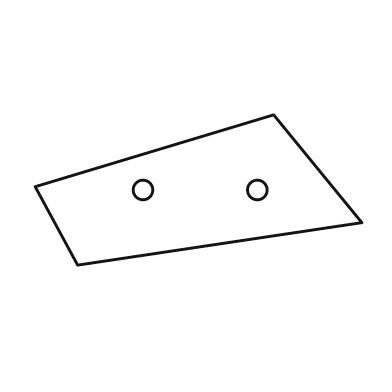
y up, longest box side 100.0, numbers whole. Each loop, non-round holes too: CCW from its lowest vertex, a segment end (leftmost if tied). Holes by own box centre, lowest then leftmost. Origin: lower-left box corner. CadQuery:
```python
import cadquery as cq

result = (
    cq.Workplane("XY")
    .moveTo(13.0, 0.0)
    .lineTo(100.0, 13.0)
    .lineTo(73.0, 46.0)
    .lineTo(0.0, 24.0)
    .close()
    .moveTo(33.0, 23.0)
    .circle(3.0)
    .moveTo(68.0, 23.0)
    .circle(3.0)
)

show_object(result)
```